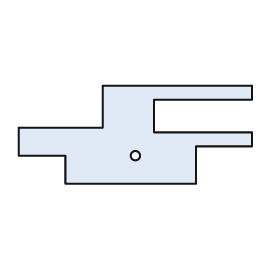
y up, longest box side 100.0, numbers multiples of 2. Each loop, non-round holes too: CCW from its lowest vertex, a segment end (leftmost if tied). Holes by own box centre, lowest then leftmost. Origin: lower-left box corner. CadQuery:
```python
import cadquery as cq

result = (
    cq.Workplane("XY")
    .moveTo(20.0, 0.0)
    .lineTo(76.0, 0.0)
    .lineTo(76.0, 16.0)
    .lineTo(100.0, 16.0)
    .lineTo(100.0, 22.0)
    .lineTo(58.0, 22.0)
    .lineTo(58.0, 36.0)
    .lineTo(100.0, 36.0)
    .lineTo(100.0, 42.0)
    .lineTo(36.0, 42.0)
    .lineTo(36.0, 24.0)
    .lineTo(0.0, 24.0)
    .lineTo(0.0, 12.0)
    .lineTo(20.0, 12.0)
    .close()
    .moveTo(50.0, 12.0)
    .circle(2.0)
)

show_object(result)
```